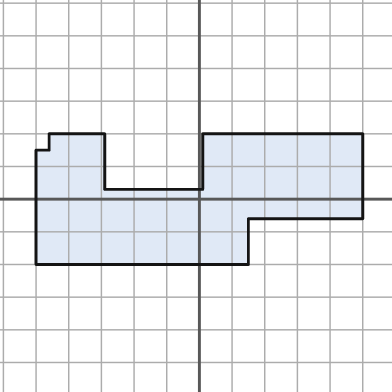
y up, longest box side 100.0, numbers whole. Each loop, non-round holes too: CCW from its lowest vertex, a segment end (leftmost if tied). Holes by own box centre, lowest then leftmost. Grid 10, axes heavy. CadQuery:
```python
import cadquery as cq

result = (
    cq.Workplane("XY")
    .moveTo(-50.0, -20.0)
    .lineTo(15.0, -20.0)
    .lineTo(15.0, -6.0)
    .lineTo(50.0, -6.0)
    .lineTo(50.0, 20.0)
    .lineTo(1.0, 20.0)
    .lineTo(1.0, 3.0)
    .lineTo(-29.0, 3.0)
    .lineTo(-29.0, 20.0)
    .lineTo(-46.0, 20.0)
    .lineTo(-46.0, 15.0)
    .lineTo(-50.0, 15.0)
    .close()
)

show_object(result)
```